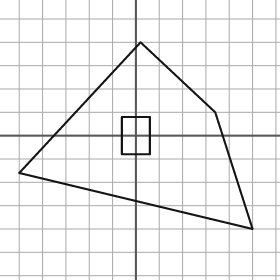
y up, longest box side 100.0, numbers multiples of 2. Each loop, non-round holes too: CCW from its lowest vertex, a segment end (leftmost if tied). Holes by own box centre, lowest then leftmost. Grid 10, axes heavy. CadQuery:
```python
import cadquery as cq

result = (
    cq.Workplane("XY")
    .moveTo(50.0, -40.0)
    .lineTo(34.0, 10.0)
    .lineTo(2.0, 40.0)
    .lineTo(-50.0, -16.0)
    .close()
    .moveTo(-6.0, -8.0)
    .lineTo(6.0, -8.0)
    .lineTo(6.0, 8.0)
    .lineTo(-6.0, 8.0)
    .close()
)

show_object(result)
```